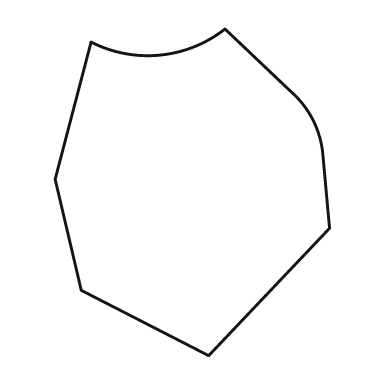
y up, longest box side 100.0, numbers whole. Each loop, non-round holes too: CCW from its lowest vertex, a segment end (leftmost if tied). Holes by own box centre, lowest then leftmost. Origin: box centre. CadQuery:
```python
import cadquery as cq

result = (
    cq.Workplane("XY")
    .moveTo(5.0, -50.0)
    .lineTo(42.0, -11.0)
    .lineTo(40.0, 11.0)
    .threePointArc((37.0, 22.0), (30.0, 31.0))
    .lineTo(10.0, 50.0)
    .threePointArc((-10.0, 42.0), (-31.0, 46.0))
    .lineTo(-42.0, 4.0)
    .lineTo(-34.0, -30.0)
    .close()
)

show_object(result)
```